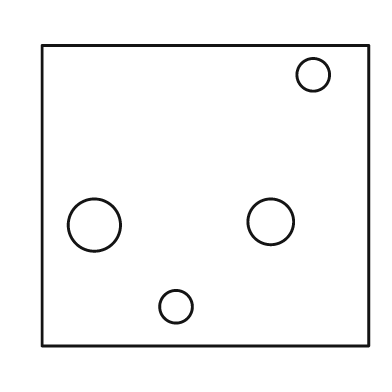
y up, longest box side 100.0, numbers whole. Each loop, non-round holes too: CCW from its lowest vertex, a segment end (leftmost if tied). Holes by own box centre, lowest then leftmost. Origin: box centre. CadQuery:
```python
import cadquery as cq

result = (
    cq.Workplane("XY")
    .moveTo(-50.0, -46.0)
    .lineTo(50.0, -46.0)
    .lineTo(50.0, 46.0)
    .lineTo(-50.0, 46.0)
    .close()
    .moveTo(-9.0, -34.0)
    .circle(5.0)
    .moveTo(-34.0, -9.0)
    .circle(8.0)
    .moveTo(20.0, -8.0)
    .circle(7.0)
    .moveTo(33.0, 37.0)
    .circle(5.0)
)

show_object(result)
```